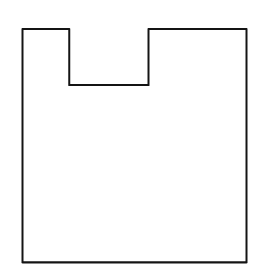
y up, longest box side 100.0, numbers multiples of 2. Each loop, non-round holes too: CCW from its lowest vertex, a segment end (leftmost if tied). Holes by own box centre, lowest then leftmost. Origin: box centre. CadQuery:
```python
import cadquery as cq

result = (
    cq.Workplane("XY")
    .moveTo(-48.0, -50.0)
    .lineTo(48.0, -50.0)
    .lineTo(48.0, 50.0)
    .lineTo(6.0, 50.0)
    .lineTo(6.0, 26.0)
    .lineTo(-28.0, 26.0)
    .lineTo(-28.0, 50.0)
    .lineTo(-48.0, 50.0)
    .close()
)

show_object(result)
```